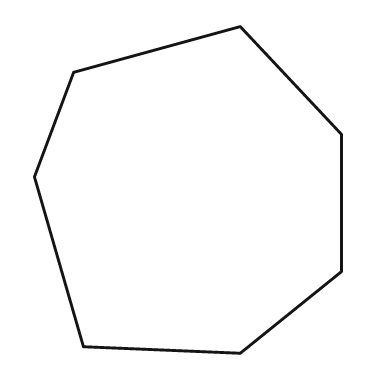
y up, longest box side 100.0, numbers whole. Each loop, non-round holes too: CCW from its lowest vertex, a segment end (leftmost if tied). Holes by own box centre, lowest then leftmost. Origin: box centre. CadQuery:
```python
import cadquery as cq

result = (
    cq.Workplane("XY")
    .moveTo(16.0, -50.0)
    .lineTo(47.0, -25.0)
    .lineTo(47.0, 17.0)
    .lineTo(16.0, 50.0)
    .lineTo(-35.0, 36.0)
    .lineTo(-47.0, 4.0)
    .lineTo(-32.0, -48.0)
    .close()
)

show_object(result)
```